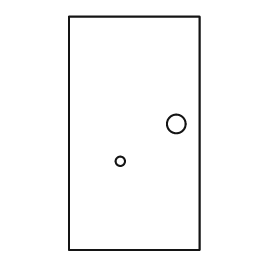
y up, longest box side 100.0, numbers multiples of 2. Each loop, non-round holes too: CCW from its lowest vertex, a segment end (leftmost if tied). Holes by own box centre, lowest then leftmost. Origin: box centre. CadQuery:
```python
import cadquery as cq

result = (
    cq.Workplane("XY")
    .moveTo(-28.0, -50.0)
    .lineTo(28.0, -50.0)
    .lineTo(28.0, 50.0)
    .lineTo(-28.0, 50.0)
    .close()
    .moveTo(-6.0, -12.0)
    .circle(2.0)
    .moveTo(18.0, 4.0)
    .circle(4.0)
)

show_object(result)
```